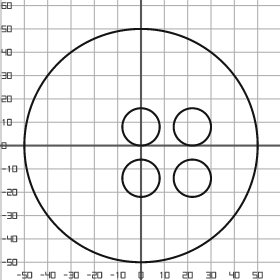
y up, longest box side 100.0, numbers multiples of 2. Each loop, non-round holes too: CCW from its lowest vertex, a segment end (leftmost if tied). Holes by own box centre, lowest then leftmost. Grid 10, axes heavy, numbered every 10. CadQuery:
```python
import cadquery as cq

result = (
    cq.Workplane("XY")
    .moveTo(0.0, 0.0)
    .circle(50.0)
    .moveTo(0.0, -14.0)
    .circle(8.0)
    .moveTo(22.0, -14.0)
    .circle(8.0)
    .moveTo(0.0, 8.0)
    .circle(8.0)
    .moveTo(22.0, 8.0)
    .circle(8.0)
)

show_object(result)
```